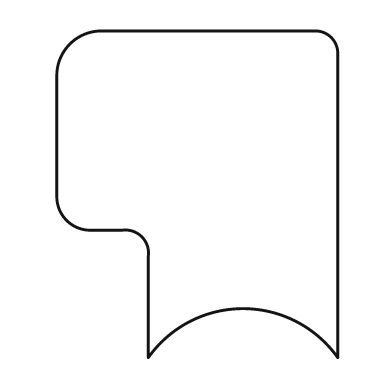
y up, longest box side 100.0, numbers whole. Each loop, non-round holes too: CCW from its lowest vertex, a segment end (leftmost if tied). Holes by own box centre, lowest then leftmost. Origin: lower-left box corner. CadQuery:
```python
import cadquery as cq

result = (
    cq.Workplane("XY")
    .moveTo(28.0, 0.0)
    .threePointArc((57.0, 15.0), (86.0, 0.0))
    .lineTo(86.0, 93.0)
    .threePointArc((84.0, 98.0), (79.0, 100.0))
    .lineTo(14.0, 100.0)
    .threePointArc((4.0, 96.0), (0.0, 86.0))
    .lineTo(0.0, 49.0)
    .threePointArc((3.0, 42.0), (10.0, 39.0))
    .lineTo(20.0, 39.0)
    .threePointArc((26.0, 37.0), (28.0, 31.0))
    .close()
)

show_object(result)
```